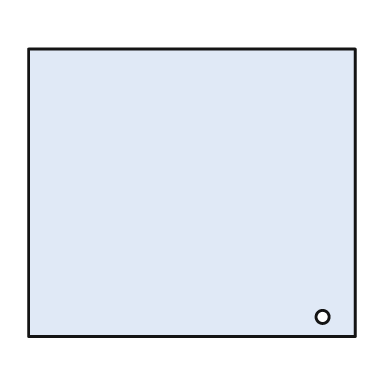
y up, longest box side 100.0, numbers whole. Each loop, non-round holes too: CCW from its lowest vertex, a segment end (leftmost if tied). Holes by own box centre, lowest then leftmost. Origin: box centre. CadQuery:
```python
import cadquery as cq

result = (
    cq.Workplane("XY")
    .moveTo(-50.0, -44.0)
    .lineTo(50.0, -44.0)
    .lineTo(50.0, 44.0)
    .lineTo(-50.0, 44.0)
    .close()
    .moveTo(40.0, -38.0)
    .circle(2.0)
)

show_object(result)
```